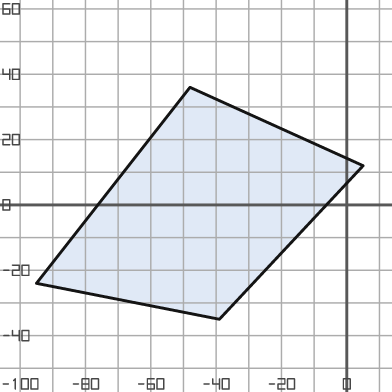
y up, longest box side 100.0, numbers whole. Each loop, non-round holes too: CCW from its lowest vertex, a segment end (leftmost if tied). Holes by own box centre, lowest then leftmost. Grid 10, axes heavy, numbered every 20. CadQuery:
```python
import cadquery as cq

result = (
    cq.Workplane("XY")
    .moveTo(-39.0, -35.0)
    .lineTo(5.0, 12.0)
    .lineTo(-48.0, 36.0)
    .lineTo(-95.0, -24.0)
    .close()
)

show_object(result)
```